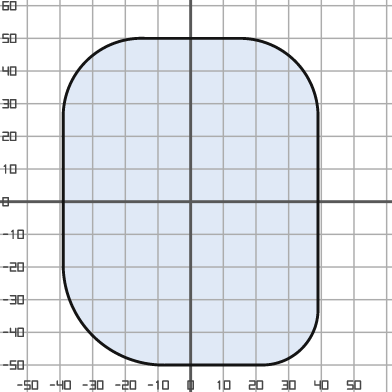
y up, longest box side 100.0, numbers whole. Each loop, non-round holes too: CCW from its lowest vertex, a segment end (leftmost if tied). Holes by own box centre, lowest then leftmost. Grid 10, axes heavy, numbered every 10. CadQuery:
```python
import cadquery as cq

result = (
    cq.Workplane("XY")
    .moveTo(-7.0, -50.0)
    .lineTo(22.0, -50.0)
    .threePointArc((34.0, -45.0), (39.0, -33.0))
    .lineTo(39.0, 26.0)
    .threePointArc((32.0, 43.0), (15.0, 50.0))
    .lineTo(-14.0, 50.0)
    .threePointArc((-32.0, 43.0), (-39.0, 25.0))
    .lineTo(-39.0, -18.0)
    .threePointArc((-30.0, -41.0), (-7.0, -50.0))
    .close()
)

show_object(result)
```